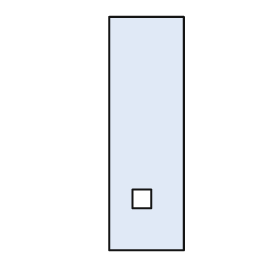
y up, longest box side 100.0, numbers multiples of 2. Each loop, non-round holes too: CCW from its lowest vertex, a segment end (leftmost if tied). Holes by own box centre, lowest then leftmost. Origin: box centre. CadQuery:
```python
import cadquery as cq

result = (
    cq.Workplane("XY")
    .moveTo(-16.0, -50.0)
    .lineTo(16.0, -50.0)
    .lineTo(16.0, 50.0)
    .lineTo(-16.0, 50.0)
    .close()
    .moveTo(-6.0, -32.0)
    .lineTo(2.0, -32.0)
    .lineTo(2.0, -24.0)
    .lineTo(-6.0, -24.0)
    .close()
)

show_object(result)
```